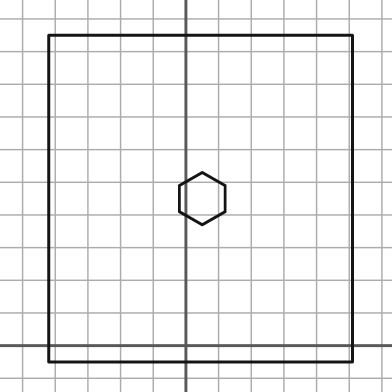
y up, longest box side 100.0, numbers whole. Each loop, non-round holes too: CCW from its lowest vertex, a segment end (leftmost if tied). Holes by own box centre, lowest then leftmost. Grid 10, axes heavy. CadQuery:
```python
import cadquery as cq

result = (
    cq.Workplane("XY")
    .moveTo(-42.0, -5.0)
    .lineTo(51.0, -5.0)
    .lineTo(51.0, 95.0)
    .lineTo(-42.0, 95.0)
    .close()
    .moveTo(5.0, 37.0)
    .lineTo(12.0, 41.0)
    .lineTo(12.0, 49.0)
    .lineTo(5.0, 53.0)
    .lineTo(-2.0, 49.0)
    .lineTo(-2.0, 41.0)
    .close()
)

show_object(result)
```